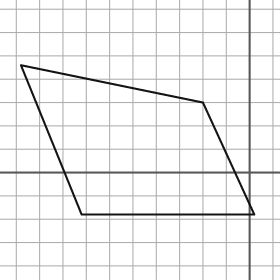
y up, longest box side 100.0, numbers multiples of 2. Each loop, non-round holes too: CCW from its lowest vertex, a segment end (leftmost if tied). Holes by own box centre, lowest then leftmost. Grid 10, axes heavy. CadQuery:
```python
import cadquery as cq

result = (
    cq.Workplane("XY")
    .moveTo(-72.0, -18.0)
    .lineTo(2.0, -18.0)
    .lineTo(-20.0, 30.0)
    .lineTo(-98.0, 46.0)
    .close()
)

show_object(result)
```